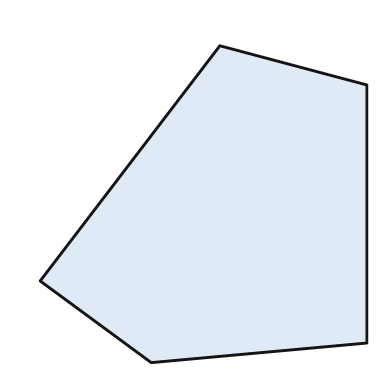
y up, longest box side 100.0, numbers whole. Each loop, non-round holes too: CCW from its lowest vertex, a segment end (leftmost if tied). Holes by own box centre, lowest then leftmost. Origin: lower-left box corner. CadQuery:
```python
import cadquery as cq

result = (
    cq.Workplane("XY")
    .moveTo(34.0, 0.0)
    .lineTo(100.0, 6.0)
    .lineTo(100.0, 85.0)
    .lineTo(55.0, 97.0)
    .lineTo(0.0, 25.0)
    .close()
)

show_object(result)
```